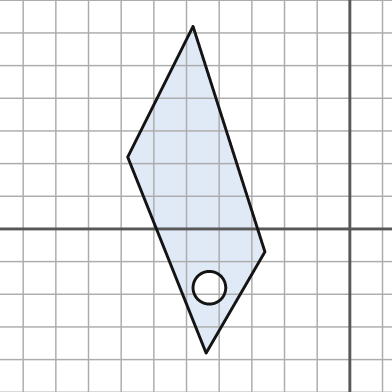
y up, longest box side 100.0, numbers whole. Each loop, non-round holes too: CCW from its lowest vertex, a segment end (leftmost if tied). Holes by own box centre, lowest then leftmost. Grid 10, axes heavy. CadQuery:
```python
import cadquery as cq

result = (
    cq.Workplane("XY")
    .moveTo(-44.0, -38.0)
    .lineTo(-26.0, -7.0)
    .lineTo(-48.0, 62.0)
    .lineTo(-68.0, 22.0)
    .close()
    .moveTo(-43.0, -18.0)
    .circle(5.0)
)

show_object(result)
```